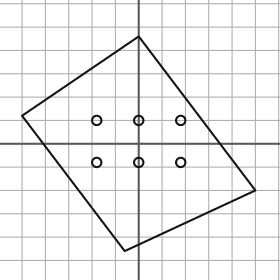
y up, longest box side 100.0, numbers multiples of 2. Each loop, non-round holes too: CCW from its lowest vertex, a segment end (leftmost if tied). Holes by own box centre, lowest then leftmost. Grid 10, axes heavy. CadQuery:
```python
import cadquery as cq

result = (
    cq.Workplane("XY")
    .moveTo(-6.0, -46.0)
    .lineTo(50.0, -20.0)
    .lineTo(0.0, 46.0)
    .lineTo(-50.0, 12.0)
    .close()
    .moveTo(-18.0, -8.0)
    .circle(2.0)
    .moveTo(0.0, -8.0)
    .circle(2.0)
    .moveTo(18.0, -8.0)
    .circle(2.0)
    .moveTo(-18.0, 10.0)
    .circle(2.0)
    .moveTo(0.0, 10.0)
    .circle(2.0)
    .moveTo(18.0, 10.0)
    .circle(2.0)
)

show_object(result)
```